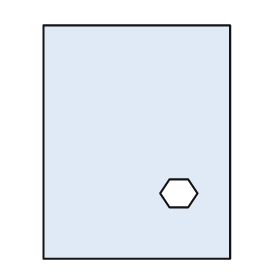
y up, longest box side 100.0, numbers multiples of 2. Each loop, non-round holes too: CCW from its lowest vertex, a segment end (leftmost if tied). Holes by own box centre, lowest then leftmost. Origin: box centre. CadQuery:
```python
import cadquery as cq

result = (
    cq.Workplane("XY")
    .moveTo(-40.0, -50.0)
    .lineTo(40.0, -50.0)
    .lineTo(40.0, 50.0)
    .lineTo(-40.0, 50.0)
    .close()
    .moveTo(14.0, -28.0)
    .lineTo(22.0, -28.0)
    .lineTo(26.0, -22.0)
    .lineTo(22.0, -16.0)
    .lineTo(14.0, -16.0)
    .lineTo(10.0, -22.0)
    .close()
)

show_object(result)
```